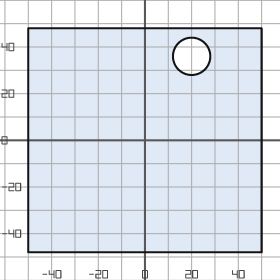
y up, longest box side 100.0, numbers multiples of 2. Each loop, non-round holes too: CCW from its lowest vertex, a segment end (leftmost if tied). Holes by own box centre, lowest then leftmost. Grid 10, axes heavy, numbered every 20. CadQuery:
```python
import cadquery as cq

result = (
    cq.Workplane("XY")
    .moveTo(-50.0, -48.0)
    .lineTo(50.0, -48.0)
    .lineTo(50.0, 48.0)
    .lineTo(-50.0, 48.0)
    .close()
    .moveTo(20.0, 36.0)
    .circle(8.0)
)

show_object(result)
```